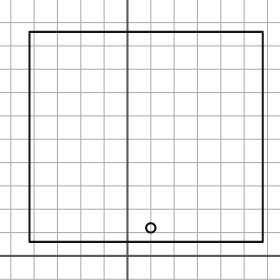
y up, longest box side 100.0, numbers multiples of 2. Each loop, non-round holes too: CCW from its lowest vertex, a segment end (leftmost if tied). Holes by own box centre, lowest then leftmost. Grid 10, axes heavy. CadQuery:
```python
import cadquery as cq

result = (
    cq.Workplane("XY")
    .moveTo(-42.0, 6.0)
    .lineTo(58.0, 6.0)
    .lineTo(58.0, 96.0)
    .lineTo(-42.0, 96.0)
    .close()
    .moveTo(10.0, 12.0)
    .circle(2.0)
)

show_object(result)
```